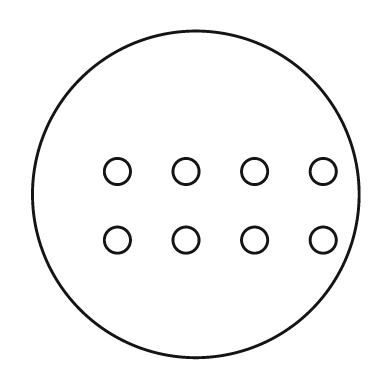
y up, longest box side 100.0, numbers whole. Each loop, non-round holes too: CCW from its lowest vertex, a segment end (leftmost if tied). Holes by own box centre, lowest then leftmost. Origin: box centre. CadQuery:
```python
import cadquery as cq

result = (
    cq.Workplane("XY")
    .moveTo(0.0, 0.0)
    .circle(50.0)
    .moveTo(-24.0, -14.0)
    .circle(4.0)
    .moveTo(-3.0, -14.0)
    .circle(4.0)
    .moveTo(18.0, -14.0)
    .circle(4.0)
    .moveTo(39.0, -14.0)
    .circle(4.0)
    .moveTo(-24.0, 7.0)
    .circle(4.0)
    .moveTo(-3.0, 7.0)
    .circle(4.0)
    .moveTo(18.0, 7.0)
    .circle(4.0)
    .moveTo(39.0, 7.0)
    .circle(4.0)
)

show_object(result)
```